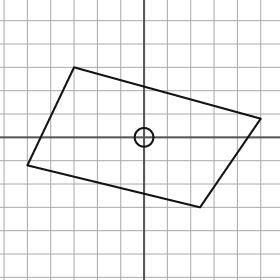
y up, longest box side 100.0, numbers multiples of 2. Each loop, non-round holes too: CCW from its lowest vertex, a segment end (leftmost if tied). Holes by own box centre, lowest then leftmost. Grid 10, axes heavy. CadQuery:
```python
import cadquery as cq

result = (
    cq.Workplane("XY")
    .moveTo(24.0, -30.0)
    .lineTo(50.0, 8.0)
    .lineTo(-30.0, 30.0)
    .lineTo(-50.0, -12.0)
    .close()
    .moveTo(0.0, 0.0)
    .circle(4.0)
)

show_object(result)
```